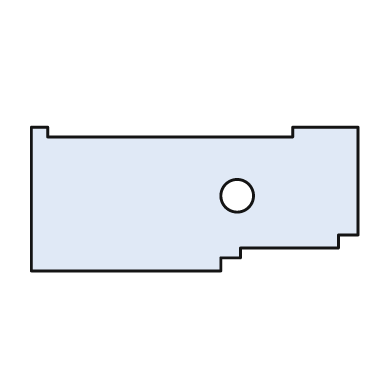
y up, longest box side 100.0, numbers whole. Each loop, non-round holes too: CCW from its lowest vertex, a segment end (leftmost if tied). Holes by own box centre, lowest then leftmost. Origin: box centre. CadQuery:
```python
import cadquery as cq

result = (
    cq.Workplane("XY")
    .moveTo(-50.0, -22.0)
    .lineTo(8.0, -22.0)
    .lineTo(8.0, -18.0)
    .lineTo(14.0, -18.0)
    .lineTo(14.0, -15.0)
    .lineTo(44.0, -15.0)
    .lineTo(44.0, -11.0)
    .lineTo(50.0, -11.0)
    .lineTo(50.0, 22.0)
    .lineTo(30.0, 22.0)
    .lineTo(30.0, 19.0)
    .lineTo(-45.0, 19.0)
    .lineTo(-45.0, 22.0)
    .lineTo(-50.0, 22.0)
    .close()
    .moveTo(13.0, 1.0)
    .circle(5.0)
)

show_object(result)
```